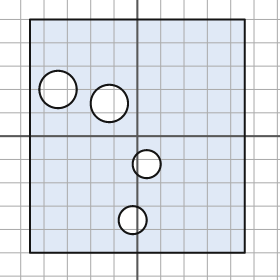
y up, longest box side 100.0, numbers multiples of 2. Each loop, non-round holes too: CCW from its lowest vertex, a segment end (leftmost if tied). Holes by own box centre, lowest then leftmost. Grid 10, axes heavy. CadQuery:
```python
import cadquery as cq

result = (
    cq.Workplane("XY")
    .moveTo(-46.0, -50.0)
    .lineTo(46.0, -50.0)
    .lineTo(46.0, 50.0)
    .lineTo(-46.0, 50.0)
    .close()
    .moveTo(-2.0, -36.0)
    .circle(6.0)
    .moveTo(4.0, -12.0)
    .circle(6.0)
    .moveTo(-12.0, 14.0)
    .circle(8.0)
    .moveTo(-34.0, 20.0)
    .circle(8.0)
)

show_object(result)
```